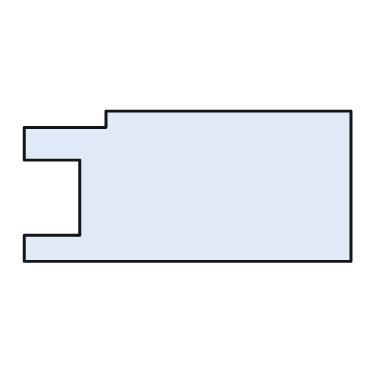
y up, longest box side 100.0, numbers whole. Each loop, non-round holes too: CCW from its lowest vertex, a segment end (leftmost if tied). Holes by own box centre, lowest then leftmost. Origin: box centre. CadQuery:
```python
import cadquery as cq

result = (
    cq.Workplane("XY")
    .moveTo(-50.0, -23.0)
    .lineTo(50.0, -23.0)
    .lineTo(50.0, 23.0)
    .lineTo(-25.0, 23.0)
    .lineTo(-25.0, 18.0)
    .lineTo(-50.0, 18.0)
    .lineTo(-50.0, 8.0)
    .lineTo(-33.0, 8.0)
    .lineTo(-33.0, -15.0)
    .lineTo(-50.0, -15.0)
    .close()
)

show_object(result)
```